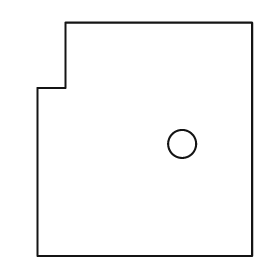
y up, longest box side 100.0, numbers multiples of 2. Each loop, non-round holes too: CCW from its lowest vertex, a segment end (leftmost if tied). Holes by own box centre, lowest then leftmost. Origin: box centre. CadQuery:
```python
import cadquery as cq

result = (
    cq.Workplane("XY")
    .moveTo(-46.0, -50.0)
    .lineTo(46.0, -50.0)
    .lineTo(46.0, 50.0)
    .lineTo(-34.0, 50.0)
    .lineTo(-34.0, 22.0)
    .lineTo(-46.0, 22.0)
    .close()
    .moveTo(16.0, -2.0)
    .circle(6.0)
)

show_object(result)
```